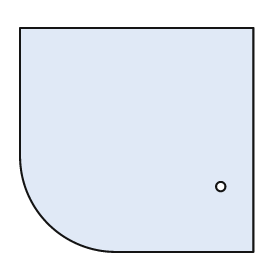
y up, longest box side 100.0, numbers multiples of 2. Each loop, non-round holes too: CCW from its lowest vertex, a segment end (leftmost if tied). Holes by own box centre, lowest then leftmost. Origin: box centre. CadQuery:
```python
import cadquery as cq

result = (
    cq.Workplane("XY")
    .moveTo(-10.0, -48.0)
    .lineTo(50.0, -48.0)
    .lineTo(50.0, 48.0)
    .lineTo(-50.0, 48.0)
    .lineTo(-50.0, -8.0)
    .threePointArc((-38.0, -36.0), (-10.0, -48.0))
    .close()
    .moveTo(36.0, -20.0)
    .circle(2.0)
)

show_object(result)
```